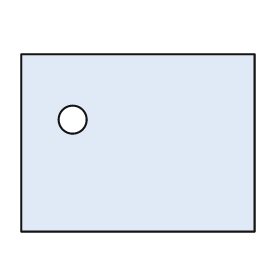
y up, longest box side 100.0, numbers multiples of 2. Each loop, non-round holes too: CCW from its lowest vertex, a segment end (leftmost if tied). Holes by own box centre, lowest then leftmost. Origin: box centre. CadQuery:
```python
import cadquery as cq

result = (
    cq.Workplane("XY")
    .moveTo(-50.0, -38.0)
    .lineTo(50.0, -38.0)
    .lineTo(50.0, 38.0)
    .lineTo(-50.0, 38.0)
    .close()
    .moveTo(-28.0, 10.0)
    .circle(6.0)
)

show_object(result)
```